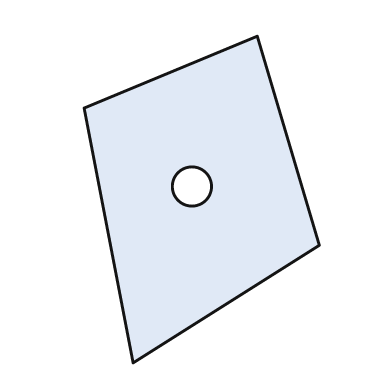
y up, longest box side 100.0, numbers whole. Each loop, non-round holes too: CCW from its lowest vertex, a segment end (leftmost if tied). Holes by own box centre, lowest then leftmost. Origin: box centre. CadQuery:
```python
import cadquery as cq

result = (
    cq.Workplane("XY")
    .moveTo(-21.0, -50.0)
    .lineTo(36.0, -14.0)
    .lineTo(17.0, 50.0)
    .lineTo(-36.0, 28.0)
    .close()
    .moveTo(-3.0, 4.0)
    .circle(6.0)
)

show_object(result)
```